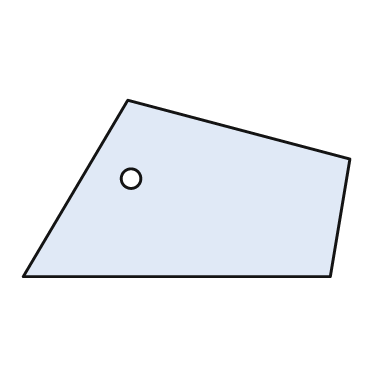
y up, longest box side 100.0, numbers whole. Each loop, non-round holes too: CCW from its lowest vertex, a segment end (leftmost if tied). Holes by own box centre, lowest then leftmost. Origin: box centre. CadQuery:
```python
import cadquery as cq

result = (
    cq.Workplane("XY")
    .moveTo(-50.0, -27.0)
    .lineTo(44.0, -27.0)
    .lineTo(50.0, 9.0)
    .lineTo(-18.0, 27.0)
    .close()
    .moveTo(-17.0, 3.0)
    .circle(3.0)
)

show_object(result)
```